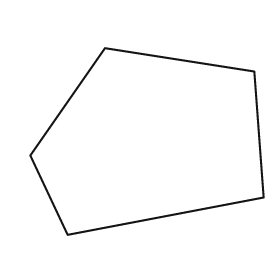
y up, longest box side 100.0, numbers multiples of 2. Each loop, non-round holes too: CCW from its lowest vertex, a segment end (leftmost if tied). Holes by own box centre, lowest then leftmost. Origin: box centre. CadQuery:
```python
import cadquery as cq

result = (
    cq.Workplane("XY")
    .moveTo(-34.0, -40.0)
    .lineTo(50.0, -24.0)
    .lineTo(46.0, 30.0)
    .lineTo(-18.0, 40.0)
    .lineTo(-50.0, -6.0)
    .close()
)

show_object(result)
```